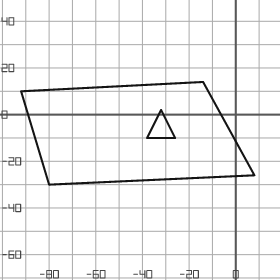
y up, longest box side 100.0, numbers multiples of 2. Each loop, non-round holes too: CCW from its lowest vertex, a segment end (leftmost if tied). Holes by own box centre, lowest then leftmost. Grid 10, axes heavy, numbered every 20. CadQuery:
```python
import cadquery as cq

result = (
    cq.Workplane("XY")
    .moveTo(-80.0, -30.0)
    .lineTo(8.0, -26.0)
    .lineTo(-14.0, 14.0)
    .lineTo(-92.0, 10.0)
    .close()
    .moveTo(-38.0, -10.0)
    .lineTo(-26.0, -10.0)
    .lineTo(-32.0, 2.0)
    .close()
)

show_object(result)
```